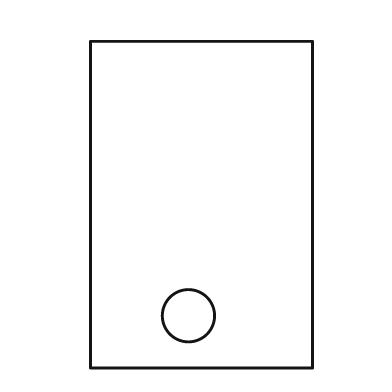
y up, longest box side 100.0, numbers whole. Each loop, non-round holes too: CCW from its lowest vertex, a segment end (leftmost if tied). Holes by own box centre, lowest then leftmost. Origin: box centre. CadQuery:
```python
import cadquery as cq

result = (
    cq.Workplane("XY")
    .moveTo(-34.0, -50.0)
    .lineTo(34.0, -50.0)
    .lineTo(34.0, 50.0)
    .lineTo(-34.0, 50.0)
    .close()
    .moveTo(-4.0, -34.0)
    .circle(8.0)
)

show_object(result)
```